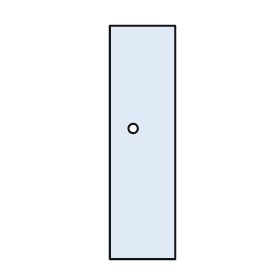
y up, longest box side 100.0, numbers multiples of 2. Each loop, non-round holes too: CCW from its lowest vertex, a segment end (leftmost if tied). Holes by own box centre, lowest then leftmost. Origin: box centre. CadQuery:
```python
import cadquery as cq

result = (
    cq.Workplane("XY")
    .moveTo(-14.0, -50.0)
    .lineTo(14.0, -50.0)
    .lineTo(14.0, 50.0)
    .lineTo(-14.0, 50.0)
    .close()
    .moveTo(-4.0, 6.0)
    .circle(2.0)
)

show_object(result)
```